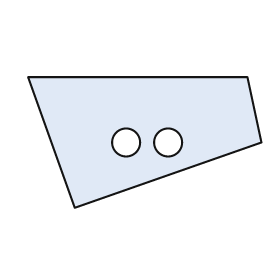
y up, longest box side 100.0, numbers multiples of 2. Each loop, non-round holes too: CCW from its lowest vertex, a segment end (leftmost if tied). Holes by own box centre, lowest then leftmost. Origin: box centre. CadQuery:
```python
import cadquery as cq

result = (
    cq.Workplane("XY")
    .moveTo(-30.0, -28.0)
    .lineTo(50.0, 0.0)
    .lineTo(44.0, 28.0)
    .lineTo(-50.0, 28.0)
    .close()
    .moveTo(-8.0, 0.0)
    .circle(6.0)
    .moveTo(10.0, 0.0)
    .circle(6.0)
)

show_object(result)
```